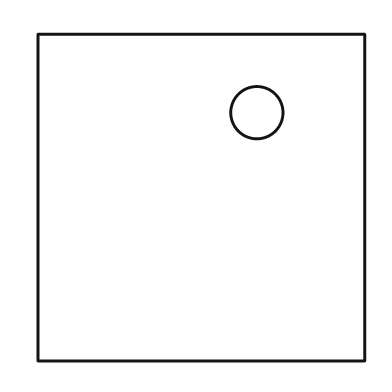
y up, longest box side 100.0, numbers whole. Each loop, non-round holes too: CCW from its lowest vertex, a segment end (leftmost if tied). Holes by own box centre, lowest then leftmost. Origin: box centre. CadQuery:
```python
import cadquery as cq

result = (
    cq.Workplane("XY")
    .moveTo(-50.0, -50.0)
    .lineTo(50.0, -50.0)
    .lineTo(50.0, 50.0)
    .lineTo(-50.0, 50.0)
    .close()
    .moveTo(17.0, 26.0)
    .circle(8.0)
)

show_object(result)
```